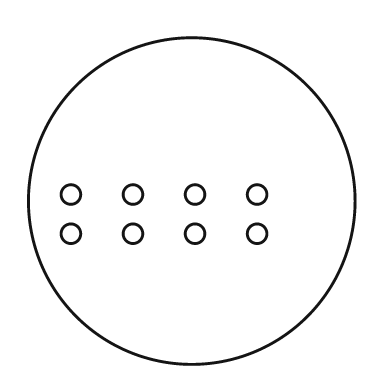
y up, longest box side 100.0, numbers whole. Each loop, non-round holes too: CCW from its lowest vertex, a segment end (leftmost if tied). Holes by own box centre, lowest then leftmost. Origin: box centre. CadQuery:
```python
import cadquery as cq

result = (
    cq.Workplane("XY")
    .moveTo(0.0, 0.0)
    .circle(50.0)
    .moveTo(-37.0, -10.0)
    .circle(3.0)
    .moveTo(-18.0, -10.0)
    .circle(3.0)
    .moveTo(1.0, -10.0)
    .circle(3.0)
    .moveTo(20.0, -10.0)
    .circle(3.0)
    .moveTo(-37.0, 2.0)
    .circle(3.0)
    .moveTo(-18.0, 2.0)
    .circle(3.0)
    .moveTo(1.0, 2.0)
    .circle(3.0)
    .moveTo(20.0, 2.0)
    .circle(3.0)
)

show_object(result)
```